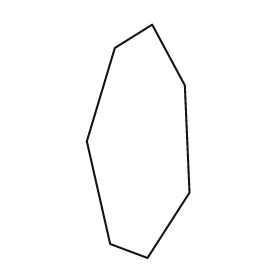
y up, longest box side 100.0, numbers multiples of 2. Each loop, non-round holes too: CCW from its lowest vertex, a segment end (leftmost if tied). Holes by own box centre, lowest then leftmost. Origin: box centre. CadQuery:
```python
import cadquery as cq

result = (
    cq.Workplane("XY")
    .moveTo(4.0, -50.0)
    .lineTo(22.0, -22.0)
    .lineTo(20.0, 24.0)
    .lineTo(6.0, 50.0)
    .lineTo(-10.0, 40.0)
    .lineTo(-22.0, 0.0)
    .lineTo(-12.0, -44.0)
    .close()
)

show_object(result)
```